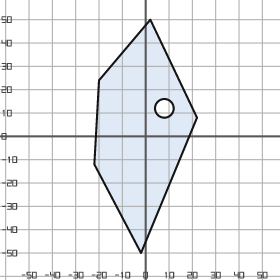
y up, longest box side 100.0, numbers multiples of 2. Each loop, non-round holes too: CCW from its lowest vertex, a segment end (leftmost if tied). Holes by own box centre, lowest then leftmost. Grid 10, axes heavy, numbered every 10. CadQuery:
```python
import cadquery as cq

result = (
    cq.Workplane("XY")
    .moveTo(-2.0, -50.0)
    .lineTo(22.0, 8.0)
    .lineTo(2.0, 50.0)
    .lineTo(-20.0, 24.0)
    .lineTo(-22.0, -12.0)
    .close()
    .moveTo(8.0, 12.0)
    .circle(4.0)
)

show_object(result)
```